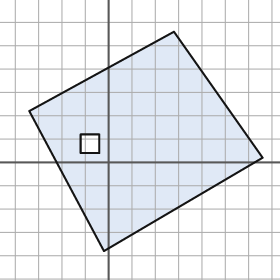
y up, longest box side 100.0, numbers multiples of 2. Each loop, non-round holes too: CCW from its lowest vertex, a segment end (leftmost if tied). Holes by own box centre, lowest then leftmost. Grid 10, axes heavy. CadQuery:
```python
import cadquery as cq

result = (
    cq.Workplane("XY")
    .moveTo(-2.0, -38.0)
    .lineTo(66.0, 2.0)
    .lineTo(28.0, 56.0)
    .lineTo(-34.0, 22.0)
    .close()
    .moveTo(-12.0, 4.0)
    .lineTo(-4.0, 4.0)
    .lineTo(-4.0, 12.0)
    .lineTo(-12.0, 12.0)
    .close()
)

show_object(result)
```